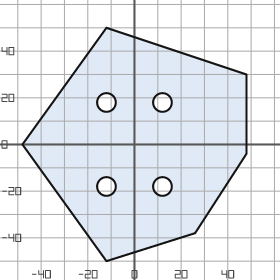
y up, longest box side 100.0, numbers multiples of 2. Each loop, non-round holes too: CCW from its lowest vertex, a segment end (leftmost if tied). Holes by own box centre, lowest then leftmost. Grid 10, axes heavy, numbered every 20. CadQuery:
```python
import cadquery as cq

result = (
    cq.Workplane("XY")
    .moveTo(-12.0, -50.0)
    .lineTo(26.0, -38.0)
    .lineTo(48.0, -4.0)
    .lineTo(48.0, 30.0)
    .lineTo(-12.0, 50.0)
    .lineTo(-48.0, 0.0)
    .close()
    .moveTo(-12.0, -18.0)
    .circle(4.0)
    .moveTo(12.0, -18.0)
    .circle(4.0)
    .moveTo(-12.0, 18.0)
    .circle(4.0)
    .moveTo(12.0, 18.0)
    .circle(4.0)
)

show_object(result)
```